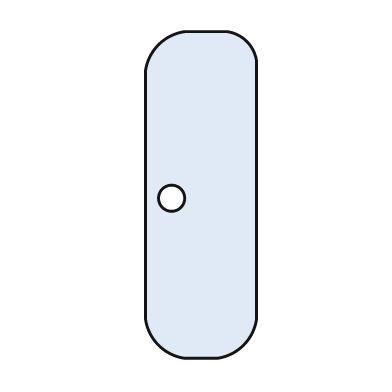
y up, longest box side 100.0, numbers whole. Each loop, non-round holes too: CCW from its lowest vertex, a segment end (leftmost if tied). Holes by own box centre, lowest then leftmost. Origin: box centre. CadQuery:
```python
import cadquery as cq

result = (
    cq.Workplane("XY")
    .moveTo(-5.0, -50.0)
    .lineTo(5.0, -50.0)
    .threePointArc((13.0, -46.0), (17.0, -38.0))
    .lineTo(17.0, 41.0)
    .threePointArc((14.0, 47.0), (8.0, 50.0))
    .lineTo(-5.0, 50.0)
    .threePointArc((-13.0, 46.0), (-17.0, 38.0))
    .lineTo(-17.0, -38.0)
    .threePointArc((-13.0, -46.0), (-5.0, -50.0))
    .close()
    .moveTo(-9.0, -1.0)
    .circle(4.0)
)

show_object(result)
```